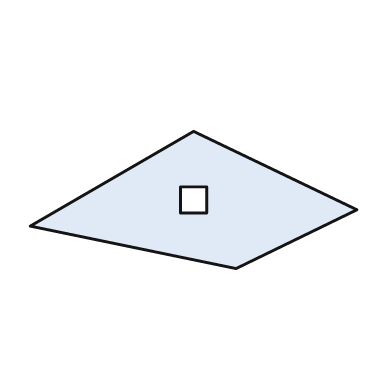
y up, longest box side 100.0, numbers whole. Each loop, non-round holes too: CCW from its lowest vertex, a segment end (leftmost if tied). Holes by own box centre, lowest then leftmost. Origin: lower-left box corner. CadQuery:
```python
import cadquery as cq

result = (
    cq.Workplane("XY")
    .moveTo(63.0, 0.0)
    .lineTo(100.0, 18.0)
    .lineTo(50.0, 42.0)
    .lineTo(0.0, 13.0)
    .close()
    .moveTo(46.0, 17.0)
    .lineTo(54.0, 17.0)
    .lineTo(54.0, 25.0)
    .lineTo(46.0, 25.0)
    .close()
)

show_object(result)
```